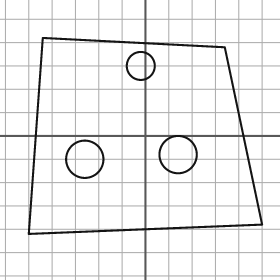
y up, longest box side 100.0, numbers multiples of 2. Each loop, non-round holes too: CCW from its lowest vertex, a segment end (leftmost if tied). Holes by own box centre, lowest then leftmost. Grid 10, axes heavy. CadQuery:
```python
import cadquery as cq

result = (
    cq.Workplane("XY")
    .moveTo(-50.0, -42.0)
    .lineTo(50.0, -38.0)
    .lineTo(34.0, 38.0)
    .lineTo(-44.0, 42.0)
    .close()
    .moveTo(-26.0, -10.0)
    .circle(8.0)
    .moveTo(14.0, -8.0)
    .circle(8.0)
    .moveTo(-2.0, 30.0)
    .circle(6.0)
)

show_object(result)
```